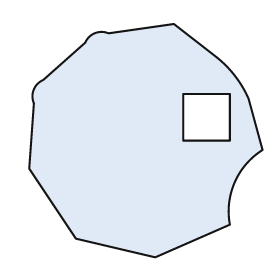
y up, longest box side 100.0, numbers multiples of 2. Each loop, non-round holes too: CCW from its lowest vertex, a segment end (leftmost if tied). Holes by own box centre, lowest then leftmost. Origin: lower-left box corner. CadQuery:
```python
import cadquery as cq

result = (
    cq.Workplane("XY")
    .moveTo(54.0, 0.0)
    .lineTo(86.0, 14.0)
    .threePointArc((88.0, 32.0), (100.0, 46.0))
    .lineTo(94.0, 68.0)
    .threePointArc((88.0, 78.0), (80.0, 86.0))
    .lineTo(62.0, 100.0)
    .lineTo(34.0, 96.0)
    .threePointArc((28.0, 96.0), (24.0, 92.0))
    .lineTo(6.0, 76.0)
    .threePointArc((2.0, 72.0), (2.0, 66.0))
    .lineTo(0.0, 38.0)
    .lineTo(20.0, 8.0)
    .close()
    .moveTo(66.0, 50.0)
    .lineTo(86.0, 50.0)
    .lineTo(86.0, 70.0)
    .lineTo(66.0, 70.0)
    .close()
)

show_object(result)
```